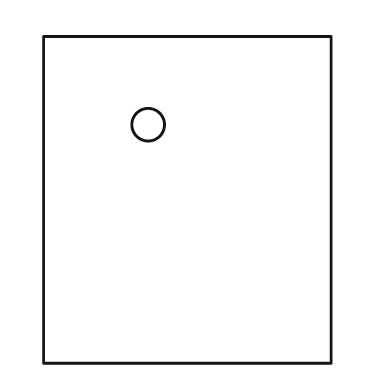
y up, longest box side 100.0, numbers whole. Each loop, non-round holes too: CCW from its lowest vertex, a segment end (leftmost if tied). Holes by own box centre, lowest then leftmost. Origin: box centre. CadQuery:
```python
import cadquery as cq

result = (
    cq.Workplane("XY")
    .moveTo(-44.0, -50.0)
    .lineTo(44.0, -50.0)
    .lineTo(44.0, 50.0)
    .lineTo(-44.0, 50.0)
    .close()
    .moveTo(-12.0, 23.0)
    .circle(5.0)
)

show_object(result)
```